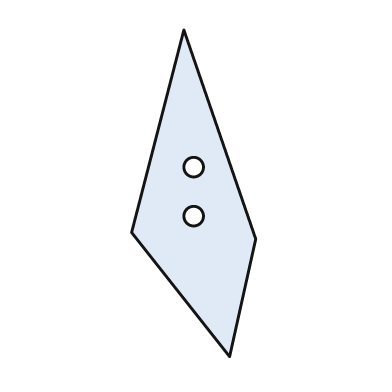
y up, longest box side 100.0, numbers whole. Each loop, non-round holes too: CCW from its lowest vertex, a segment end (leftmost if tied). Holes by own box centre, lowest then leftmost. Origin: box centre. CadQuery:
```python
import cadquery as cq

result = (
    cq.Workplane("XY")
    .moveTo(11.0, -50.0)
    .lineTo(19.0, -14.0)
    .lineTo(-3.0, 50.0)
    .lineTo(-19.0, -12.0)
    .close()
    .moveTo(0.0, -7.0)
    .circle(3.0)
    .moveTo(0.0, 8.0)
    .circle(3.0)
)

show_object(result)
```